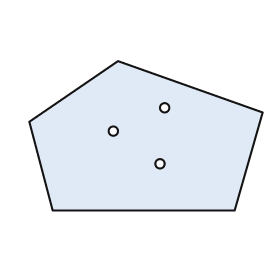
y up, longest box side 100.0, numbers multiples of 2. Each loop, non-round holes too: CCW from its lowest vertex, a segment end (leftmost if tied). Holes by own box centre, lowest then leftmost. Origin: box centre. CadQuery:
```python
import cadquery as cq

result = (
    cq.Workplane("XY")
    .moveTo(-40.0, -32.0)
    .lineTo(38.0, -32.0)
    .lineTo(50.0, 10.0)
    .lineTo(-12.0, 32.0)
    .lineTo(-50.0, 6.0)
    .close()
    .moveTo(6.0, -12.0)
    .circle(2.0)
    .moveTo(-14.0, 2.0)
    .circle(2.0)
    .moveTo(8.0, 12.0)
    .circle(2.0)
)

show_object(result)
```